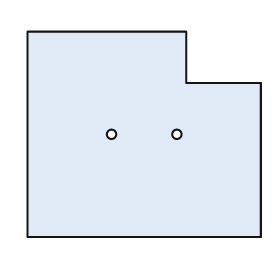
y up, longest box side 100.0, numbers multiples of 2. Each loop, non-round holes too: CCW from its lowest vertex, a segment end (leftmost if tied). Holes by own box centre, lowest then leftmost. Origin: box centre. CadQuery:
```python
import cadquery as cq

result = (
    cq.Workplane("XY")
    .moveTo(-50.0, -44.0)
    .lineTo(50.0, -44.0)
    .lineTo(50.0, 22.0)
    .lineTo(18.0, 22.0)
    .lineTo(18.0, 44.0)
    .lineTo(-50.0, 44.0)
    .close()
    .moveTo(-14.0, 0.0)
    .circle(2.0)
    .moveTo(14.0, 0.0)
    .circle(2.0)
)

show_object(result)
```